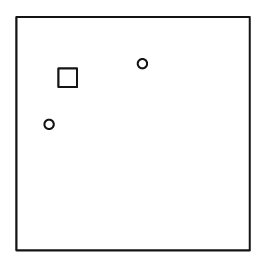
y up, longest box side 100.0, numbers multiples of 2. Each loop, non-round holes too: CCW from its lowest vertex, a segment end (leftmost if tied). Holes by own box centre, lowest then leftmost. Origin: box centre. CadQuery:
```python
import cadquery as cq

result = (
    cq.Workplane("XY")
    .moveTo(-50.0, -50.0)
    .lineTo(50.0, -50.0)
    .lineTo(50.0, 50.0)
    .lineTo(-50.0, 50.0)
    .close()
    .moveTo(-36.0, 4.0)
    .circle(2.0)
    .moveTo(-32.0, 20.0)
    .lineTo(-24.0, 20.0)
    .lineTo(-24.0, 28.0)
    .lineTo(-32.0, 28.0)
    .close()
    .moveTo(4.0, 30.0)
    .circle(2.0)
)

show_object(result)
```